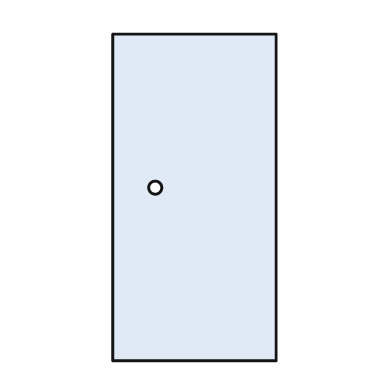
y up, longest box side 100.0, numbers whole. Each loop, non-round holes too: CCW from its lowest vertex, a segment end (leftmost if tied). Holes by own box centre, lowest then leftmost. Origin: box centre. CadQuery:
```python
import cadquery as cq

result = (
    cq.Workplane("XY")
    .moveTo(-25.0, -50.0)
    .lineTo(25.0, -50.0)
    .lineTo(25.0, 50.0)
    .lineTo(-25.0, 50.0)
    .close()
    .moveTo(-12.0, 3.0)
    .circle(2.0)
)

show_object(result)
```